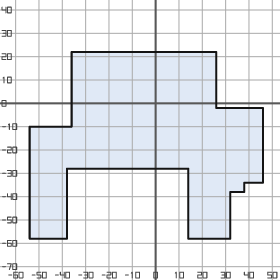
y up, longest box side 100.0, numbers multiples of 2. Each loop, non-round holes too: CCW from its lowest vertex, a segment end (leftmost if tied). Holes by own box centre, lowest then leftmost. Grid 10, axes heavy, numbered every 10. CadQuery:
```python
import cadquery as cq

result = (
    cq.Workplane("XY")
    .moveTo(-54.0, -58.0)
    .lineTo(-38.0, -58.0)
    .lineTo(-38.0, -28.0)
    .lineTo(14.0, -28.0)
    .lineTo(14.0, -58.0)
    .lineTo(32.0, -58.0)
    .lineTo(32.0, -38.0)
    .lineTo(38.0, -38.0)
    .lineTo(38.0, -34.0)
    .lineTo(46.0, -34.0)
    .lineTo(46.0, -2.0)
    .lineTo(26.0, -2.0)
    .lineTo(26.0, 22.0)
    .lineTo(-36.0, 22.0)
    .lineTo(-36.0, -10.0)
    .lineTo(-54.0, -10.0)
    .close()
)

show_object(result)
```